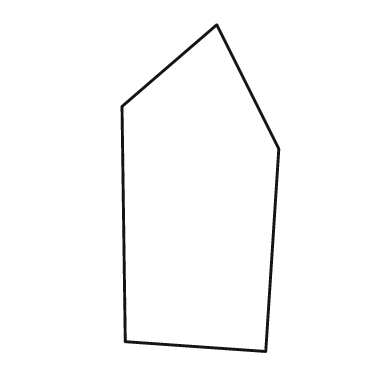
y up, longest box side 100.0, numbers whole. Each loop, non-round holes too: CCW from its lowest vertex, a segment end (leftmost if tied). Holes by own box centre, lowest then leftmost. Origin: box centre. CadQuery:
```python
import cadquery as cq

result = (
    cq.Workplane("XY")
    .moveTo(20.0, -50.0)
    .lineTo(24.0, 12.0)
    .lineTo(5.0, 50.0)
    .lineTo(-24.0, 25.0)
    .lineTo(-23.0, -47.0)
    .close()
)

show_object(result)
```